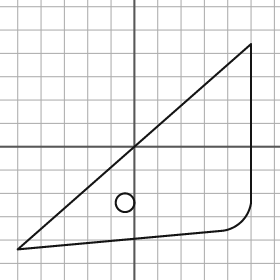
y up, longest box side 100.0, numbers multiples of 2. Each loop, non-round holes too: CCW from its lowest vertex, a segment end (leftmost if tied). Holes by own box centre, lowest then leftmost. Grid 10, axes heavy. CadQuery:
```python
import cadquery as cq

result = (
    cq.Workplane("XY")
    .moveTo(-50.0, -44.0)
    .lineTo(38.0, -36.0)
    .threePointArc((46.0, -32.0), (50.0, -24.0))
    .lineTo(50.0, 44.0)
    .close()
    .moveTo(-4.0, -24.0)
    .circle(4.0)
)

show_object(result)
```